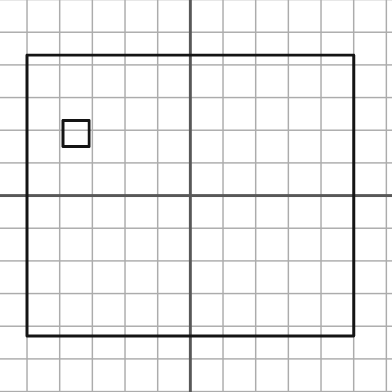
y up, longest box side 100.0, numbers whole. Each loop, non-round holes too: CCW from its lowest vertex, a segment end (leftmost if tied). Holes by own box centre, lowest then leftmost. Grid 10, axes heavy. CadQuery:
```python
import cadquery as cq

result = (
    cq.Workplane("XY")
    .moveTo(-50.0, -43.0)
    .lineTo(50.0, -43.0)
    .lineTo(50.0, 43.0)
    .lineTo(-50.0, 43.0)
    .close()
    .moveTo(-39.0, 15.0)
    .lineTo(-31.0, 15.0)
    .lineTo(-31.0, 23.0)
    .lineTo(-39.0, 23.0)
    .close()
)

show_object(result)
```